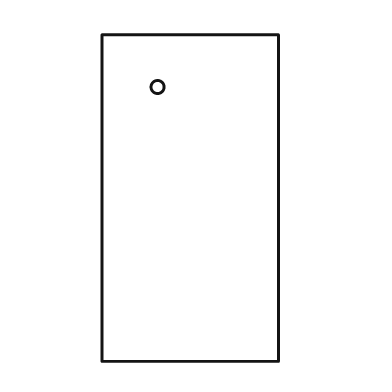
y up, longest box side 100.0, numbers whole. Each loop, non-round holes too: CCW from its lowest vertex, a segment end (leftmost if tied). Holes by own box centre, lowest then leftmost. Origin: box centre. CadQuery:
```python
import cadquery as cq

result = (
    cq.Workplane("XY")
    .moveTo(-27.0, -50.0)
    .lineTo(27.0, -50.0)
    .lineTo(27.0, 50.0)
    .lineTo(-27.0, 50.0)
    .close()
    .moveTo(-10.0, 34.0)
    .circle(2.0)
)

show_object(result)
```